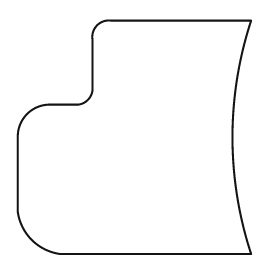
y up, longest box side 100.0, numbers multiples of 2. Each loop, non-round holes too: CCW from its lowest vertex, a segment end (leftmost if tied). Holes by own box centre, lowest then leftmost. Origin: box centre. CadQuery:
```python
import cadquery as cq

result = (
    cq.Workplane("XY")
    .moveTo(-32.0, -50.0)
    .lineTo(50.0, -50.0)
    .threePointArc((42.0, 0.0), (50.0, 50.0))
    .lineTo(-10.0, 50.0)
    .threePointArc((-16.0, 48.0), (-18.0, 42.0))
    .lineTo(-18.0, 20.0)
    .threePointArc((-20.0, 16.0), (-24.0, 14.0))
    .lineTo(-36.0, 14.0)
    .threePointArc((-46.0, 10.0), (-50.0, 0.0))
    .lineTo(-50.0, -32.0)
    .threePointArc((-44.0, -44.0), (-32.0, -50.0))
    .close()
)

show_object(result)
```